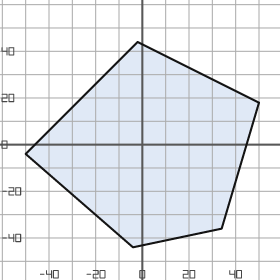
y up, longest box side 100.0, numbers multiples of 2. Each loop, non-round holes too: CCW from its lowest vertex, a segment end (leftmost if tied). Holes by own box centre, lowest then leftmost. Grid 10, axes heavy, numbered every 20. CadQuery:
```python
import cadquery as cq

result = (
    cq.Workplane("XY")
    .moveTo(-4.0, -44.0)
    .lineTo(34.0, -36.0)
    .lineTo(50.0, 18.0)
    .lineTo(-2.0, 44.0)
    .lineTo(-50.0, -4.0)
    .close()
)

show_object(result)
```